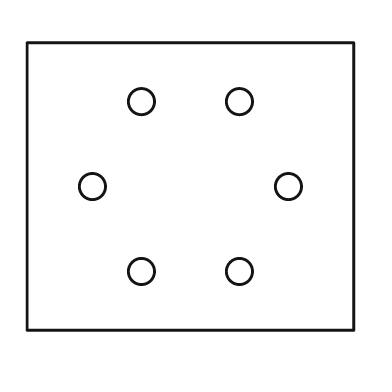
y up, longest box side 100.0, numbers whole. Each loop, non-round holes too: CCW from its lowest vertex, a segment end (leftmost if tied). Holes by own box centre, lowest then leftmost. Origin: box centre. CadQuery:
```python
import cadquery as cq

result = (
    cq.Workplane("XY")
    .moveTo(-50.0, -44.0)
    .lineTo(50.0, -44.0)
    .lineTo(50.0, 44.0)
    .lineTo(-50.0, 44.0)
    .close()
    .moveTo(-15.0, -26.0)
    .circle(4.0)
    .moveTo(15.0, -26.0)
    .circle(4.0)
    .moveTo(-30.0, 0.0)
    .circle(4.0)
    .moveTo(30.0, 0.0)
    .circle(4.0)
    .moveTo(-15.0, 26.0)
    .circle(4.0)
    .moveTo(15.0, 26.0)
    .circle(4.0)
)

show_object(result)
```